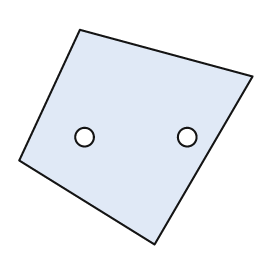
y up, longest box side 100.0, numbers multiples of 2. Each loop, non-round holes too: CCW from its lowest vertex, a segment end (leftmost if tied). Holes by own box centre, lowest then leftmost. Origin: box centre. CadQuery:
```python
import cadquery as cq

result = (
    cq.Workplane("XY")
    .moveTo(8.0, -46.0)
    .lineTo(50.0, 26.0)
    .lineTo(-24.0, 46.0)
    .lineTo(-50.0, -10.0)
    .close()
    .moveTo(-22.0, 0.0)
    .circle(4.0)
    .moveTo(22.0, 0.0)
    .circle(4.0)
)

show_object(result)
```